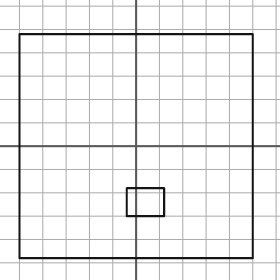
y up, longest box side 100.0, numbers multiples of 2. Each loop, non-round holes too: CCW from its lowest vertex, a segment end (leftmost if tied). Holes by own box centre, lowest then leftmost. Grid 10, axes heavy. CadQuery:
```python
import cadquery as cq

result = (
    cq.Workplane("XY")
    .moveTo(-50.0, -48.0)
    .lineTo(50.0, -48.0)
    .lineTo(50.0, 48.0)
    .lineTo(-50.0, 48.0)
    .close()
    .moveTo(-4.0, -30.0)
    .lineTo(12.0, -30.0)
    .lineTo(12.0, -18.0)
    .lineTo(-4.0, -18.0)
    .close()
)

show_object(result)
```